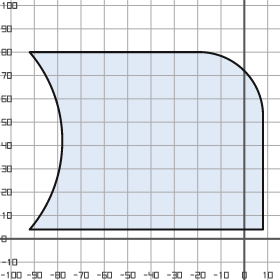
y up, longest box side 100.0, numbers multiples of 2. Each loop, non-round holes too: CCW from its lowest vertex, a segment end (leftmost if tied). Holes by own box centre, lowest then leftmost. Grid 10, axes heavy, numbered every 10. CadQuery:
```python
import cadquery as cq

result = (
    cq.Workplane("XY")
    .moveTo(-92.0, 4.0)
    .lineTo(8.0, 4.0)
    .lineTo(8.0, 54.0)
    .threePointArc((0.0, 72.0), (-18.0, 80.0))
    .lineTo(-92.0, 80.0)
    .threePointArc((-78.0, 42.0), (-92.0, 4.0))
    .close()
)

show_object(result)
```